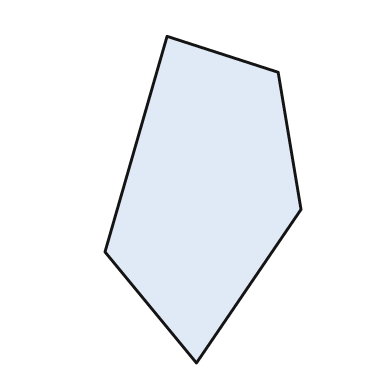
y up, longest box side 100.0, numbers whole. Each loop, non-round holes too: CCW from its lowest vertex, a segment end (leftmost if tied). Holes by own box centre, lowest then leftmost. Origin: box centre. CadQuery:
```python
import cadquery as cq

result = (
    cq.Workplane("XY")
    .moveTo(-2.0, -50.0)
    .lineTo(30.0, -3.0)
    .lineTo(23.0, 39.0)
    .lineTo(-11.0, 50.0)
    .lineTo(-30.0, -16.0)
    .close()
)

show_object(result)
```